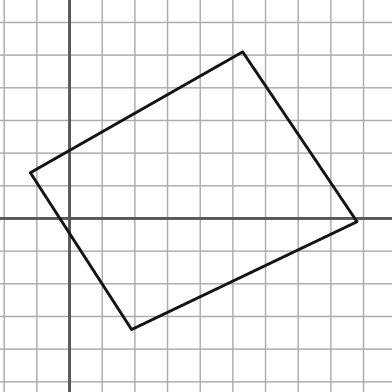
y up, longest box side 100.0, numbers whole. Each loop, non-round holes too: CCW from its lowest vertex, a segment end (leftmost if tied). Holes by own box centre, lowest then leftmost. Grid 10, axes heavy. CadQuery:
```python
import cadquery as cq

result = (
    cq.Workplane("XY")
    .moveTo(19.0, -34.0)
    .lineTo(88.0, -1.0)
    .lineTo(53.0, 51.0)
    .lineTo(-12.0, 14.0)
    .close()
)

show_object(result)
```